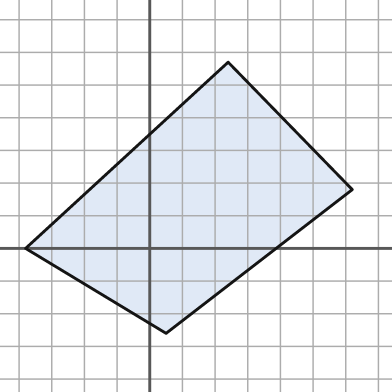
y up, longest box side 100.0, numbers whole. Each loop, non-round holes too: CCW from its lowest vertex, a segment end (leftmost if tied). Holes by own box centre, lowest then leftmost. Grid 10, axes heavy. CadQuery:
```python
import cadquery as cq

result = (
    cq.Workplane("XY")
    .moveTo(5.0, -26.0)
    .lineTo(62.0, 18.0)
    .lineTo(24.0, 57.0)
    .lineTo(-38.0, 0.0)
    .close()
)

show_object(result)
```